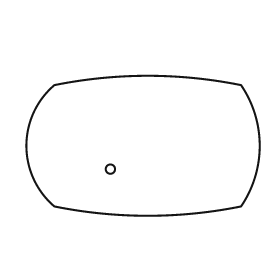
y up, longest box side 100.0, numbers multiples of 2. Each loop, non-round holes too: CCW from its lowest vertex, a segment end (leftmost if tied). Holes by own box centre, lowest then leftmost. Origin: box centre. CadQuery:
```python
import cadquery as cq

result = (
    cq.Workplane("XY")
    .moveTo(-38.0, -26.0)
    .threePointArc((2.0, -30.0), (42.0, -26.0))
    .threePointArc((50.0, 0.0), (42.0, 26.0))
    .threePointArc((2.0, 30.0), (-38.0, 26.0))
    .threePointArc((-50.0, 0.0), (-38.0, -26.0))
    .close()
    .moveTo(-14.0, -10.0)
    .circle(2.0)
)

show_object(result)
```